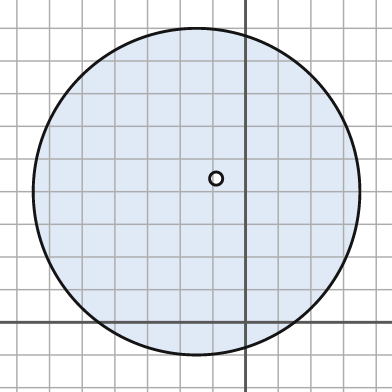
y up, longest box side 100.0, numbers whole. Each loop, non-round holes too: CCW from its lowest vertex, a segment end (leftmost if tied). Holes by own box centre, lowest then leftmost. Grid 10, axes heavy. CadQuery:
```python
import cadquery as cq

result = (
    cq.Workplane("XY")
    .moveTo(-15.0, 40.0)
    .circle(50.0)
    .moveTo(-9.0, 44.0)
    .circle(2.0)
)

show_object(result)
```